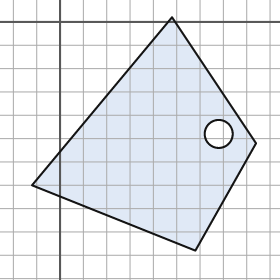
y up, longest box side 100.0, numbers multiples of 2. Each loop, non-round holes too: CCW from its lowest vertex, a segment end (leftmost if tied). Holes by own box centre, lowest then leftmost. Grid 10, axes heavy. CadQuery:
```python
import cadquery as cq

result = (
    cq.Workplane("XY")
    .moveTo(58.0, -98.0)
    .lineTo(84.0, -52.0)
    .lineTo(48.0, 2.0)
    .lineTo(-12.0, -70.0)
    .close()
    .moveTo(68.0, -48.0)
    .circle(6.0)
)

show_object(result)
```